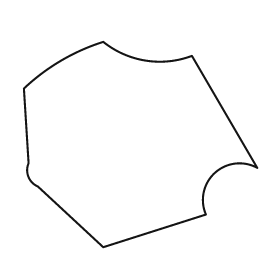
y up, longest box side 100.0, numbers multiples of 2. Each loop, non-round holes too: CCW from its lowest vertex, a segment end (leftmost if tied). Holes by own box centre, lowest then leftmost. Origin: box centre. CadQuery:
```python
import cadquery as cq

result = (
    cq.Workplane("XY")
    .moveTo(-16.0, -44.0)
    .lineTo(28.0, -30.0)
    .threePointArc((32.0, -12.0), (50.0, -10.0))
    .lineTo(22.0, 38.0)
    .threePointArc((2.0, 36.0), (-16.0, 44.0))
    .threePointArc((-34.0, 36.0), (-50.0, 24.0))
    .lineTo(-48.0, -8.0)
    .threePointArc((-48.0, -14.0), (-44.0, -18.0))
    .close()
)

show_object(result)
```